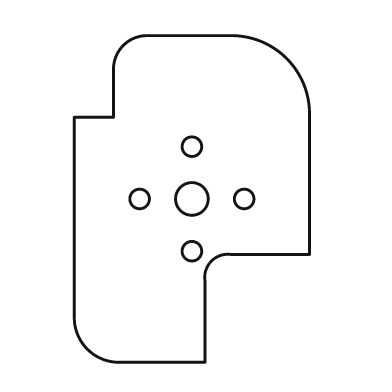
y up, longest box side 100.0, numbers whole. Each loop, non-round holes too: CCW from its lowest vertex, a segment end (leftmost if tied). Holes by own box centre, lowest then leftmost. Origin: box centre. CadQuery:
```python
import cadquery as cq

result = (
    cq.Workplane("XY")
    .moveTo(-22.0, -50.0)
    .lineTo(4.0, -50.0)
    .lineTo(4.0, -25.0)
    .threePointArc((6.0, -19.0), (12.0, -17.0))
    .lineTo(36.0, -17.0)
    .lineTo(36.0, 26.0)
    .threePointArc((29.0, 43.0), (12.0, 50.0))
    .lineTo(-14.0, 50.0)
    .threePointArc((-21.0, 47.0), (-24.0, 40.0))
    .lineTo(-24.0, 25.0)
    .lineTo(-36.0, 25.0)
    .lineTo(-36.0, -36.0)
    .threePointArc((-32.0, -46.0), (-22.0, -50.0))
    .close()
    .moveTo(0.0, -16.0)
    .circle(3.0)
    .moveTo(-16.0, 0.0)
    .circle(3.0)
    .moveTo(0.0, 0.0)
    .circle(5.0)
    .moveTo(16.0, 0.0)
    .circle(3.0)
    .moveTo(0.0, 16.0)
    .circle(3.0)
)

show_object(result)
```